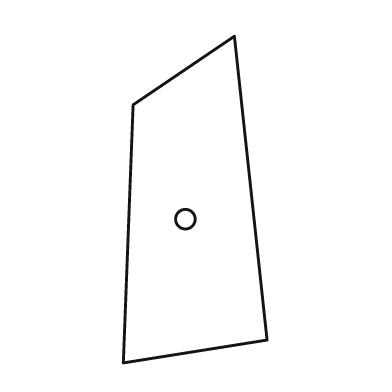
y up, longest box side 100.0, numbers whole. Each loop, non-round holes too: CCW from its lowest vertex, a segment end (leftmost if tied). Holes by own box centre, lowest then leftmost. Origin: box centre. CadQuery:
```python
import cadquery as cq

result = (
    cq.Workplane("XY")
    .moveTo(-22.0, -50.0)
    .lineTo(22.0, -43.0)
    .lineTo(12.0, 50.0)
    .lineTo(-19.0, 29.0)
    .close()
    .moveTo(-3.0, -6.0)
    .circle(3.0)
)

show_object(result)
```